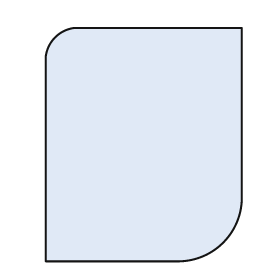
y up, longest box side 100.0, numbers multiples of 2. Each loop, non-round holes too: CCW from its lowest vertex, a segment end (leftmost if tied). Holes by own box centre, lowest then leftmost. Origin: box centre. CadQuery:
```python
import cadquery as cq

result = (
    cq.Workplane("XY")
    .moveTo(-42.0, -50.0)
    .lineTo(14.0, -50.0)
    .threePointArc((34.0, -42.0), (42.0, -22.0))
    .lineTo(42.0, 50.0)
    .lineTo(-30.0, 50.0)
    .threePointArc((-38.0, 46.0), (-42.0, 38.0))
    .close()
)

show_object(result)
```